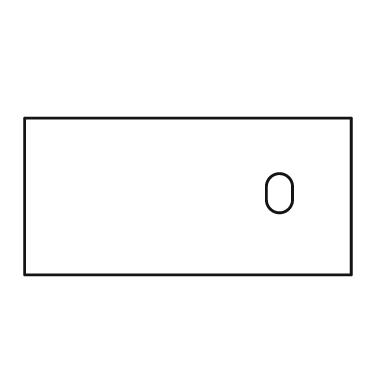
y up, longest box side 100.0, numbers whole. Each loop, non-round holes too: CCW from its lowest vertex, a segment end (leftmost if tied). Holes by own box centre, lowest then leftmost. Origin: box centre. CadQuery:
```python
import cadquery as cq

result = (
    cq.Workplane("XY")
    .moveTo(-50.0, -24.0)
    .lineTo(50.0, -24.0)
    .lineTo(50.0, 24.0)
    .lineTo(-50.0, 24.0)
    .close()
    .moveTo(24.0, -1.0)
    .threePointArc((28.0, -5.0), (32.0, -1.0))
    .lineTo(32.0, 3.0)
    .threePointArc((28.0, 7.0), (24.0, 3.0))
    .close()
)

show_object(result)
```